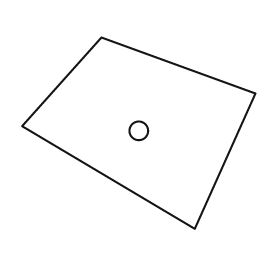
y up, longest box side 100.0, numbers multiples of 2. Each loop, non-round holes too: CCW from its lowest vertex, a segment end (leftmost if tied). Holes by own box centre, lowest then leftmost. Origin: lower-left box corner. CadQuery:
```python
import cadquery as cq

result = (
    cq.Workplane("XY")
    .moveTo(74.0, 0.0)
    .lineTo(100.0, 58.0)
    .lineTo(34.0, 82.0)
    .lineTo(0.0, 44.0)
    .close()
    .moveTo(50.0, 42.0)
    .circle(4.0)
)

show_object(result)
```